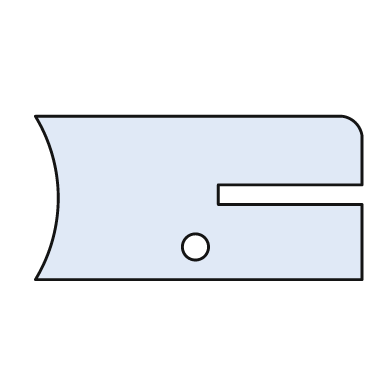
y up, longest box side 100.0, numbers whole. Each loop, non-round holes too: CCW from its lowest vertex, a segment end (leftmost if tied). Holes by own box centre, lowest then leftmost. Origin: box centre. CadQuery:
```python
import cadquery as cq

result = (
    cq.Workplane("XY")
    .moveTo(-50.0, -25.0)
    .lineTo(50.0, -25.0)
    .lineTo(50.0, -2.0)
    .lineTo(6.0, -2.0)
    .lineTo(6.0, 4.0)
    .lineTo(50.0, 4.0)
    .lineTo(50.0, 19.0)
    .threePointArc((48.0, 23.0), (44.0, 25.0))
    .lineTo(-50.0, 25.0)
    .threePointArc((-43.0, 0.0), (-50.0, -25.0))
    .close()
    .moveTo(-1.0, -15.0)
    .circle(4.0)
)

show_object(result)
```